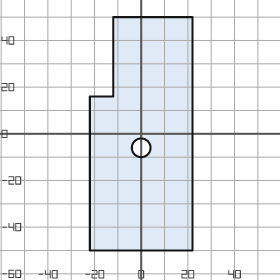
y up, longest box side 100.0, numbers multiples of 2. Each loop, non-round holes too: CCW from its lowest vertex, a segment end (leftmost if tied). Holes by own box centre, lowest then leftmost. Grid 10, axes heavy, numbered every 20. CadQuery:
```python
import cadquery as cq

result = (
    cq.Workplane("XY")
    .moveTo(-22.0, -50.0)
    .lineTo(22.0, -50.0)
    .lineTo(22.0, 50.0)
    .lineTo(-12.0, 50.0)
    .lineTo(-12.0, 16.0)
    .lineTo(-22.0, 16.0)
    .close()
    .moveTo(0.0, -6.0)
    .circle(4.0)
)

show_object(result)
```